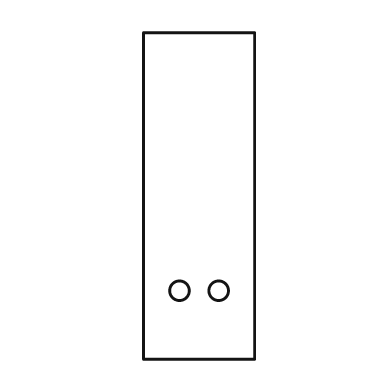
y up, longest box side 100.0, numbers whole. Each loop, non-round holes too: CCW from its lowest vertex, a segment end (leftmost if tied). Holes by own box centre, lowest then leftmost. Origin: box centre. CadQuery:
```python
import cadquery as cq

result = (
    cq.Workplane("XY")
    .moveTo(-17.0, -50.0)
    .lineTo(17.0, -50.0)
    .lineTo(17.0, 50.0)
    .lineTo(-17.0, 50.0)
    .close()
    .moveTo(-6.0, -29.0)
    .circle(3.0)
    .moveTo(6.0, -29.0)
    .circle(3.0)
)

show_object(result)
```